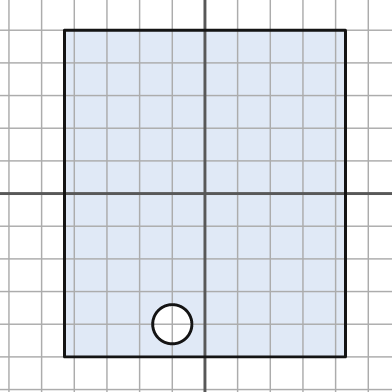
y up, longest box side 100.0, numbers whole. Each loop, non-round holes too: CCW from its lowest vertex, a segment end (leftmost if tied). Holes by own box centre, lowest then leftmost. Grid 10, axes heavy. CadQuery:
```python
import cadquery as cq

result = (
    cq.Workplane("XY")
    .moveTo(-43.0, -50.0)
    .lineTo(43.0, -50.0)
    .lineTo(43.0, 50.0)
    .lineTo(-43.0, 50.0)
    .close()
    .moveTo(-10.0, -40.0)
    .circle(6.0)
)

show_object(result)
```